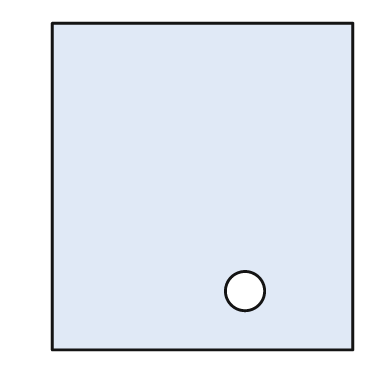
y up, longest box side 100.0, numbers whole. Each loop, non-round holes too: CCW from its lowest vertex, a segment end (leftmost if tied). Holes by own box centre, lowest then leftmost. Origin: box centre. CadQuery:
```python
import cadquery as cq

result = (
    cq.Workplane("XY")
    .moveTo(-46.0, -50.0)
    .lineTo(46.0, -50.0)
    .lineTo(46.0, 50.0)
    .lineTo(-46.0, 50.0)
    .close()
    .moveTo(13.0, -32.0)
    .circle(6.0)
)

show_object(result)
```